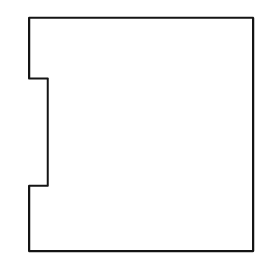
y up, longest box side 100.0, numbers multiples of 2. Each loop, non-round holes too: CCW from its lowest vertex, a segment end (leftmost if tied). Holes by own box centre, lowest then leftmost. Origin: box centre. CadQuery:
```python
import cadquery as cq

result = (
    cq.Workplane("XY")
    .moveTo(-48.0, -50.0)
    .lineTo(48.0, -50.0)
    .lineTo(48.0, 50.0)
    .lineTo(-48.0, 50.0)
    .lineTo(-48.0, 24.0)
    .lineTo(-40.0, 24.0)
    .lineTo(-40.0, -22.0)
    .lineTo(-48.0, -22.0)
    .close()
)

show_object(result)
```